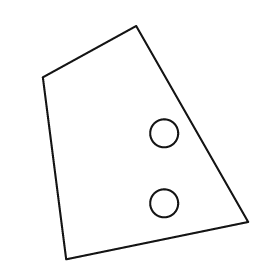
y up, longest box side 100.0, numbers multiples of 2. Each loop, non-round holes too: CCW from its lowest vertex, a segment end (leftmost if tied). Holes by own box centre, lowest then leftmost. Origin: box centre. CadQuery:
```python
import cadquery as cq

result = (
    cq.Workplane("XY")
    .moveTo(-34.0, -50.0)
    .lineTo(44.0, -34.0)
    .lineTo(-4.0, 50.0)
    .lineTo(-44.0, 28.0)
    .close()
    .moveTo(8.0, -26.0)
    .circle(6.0)
    .moveTo(8.0, 4.0)
    .circle(6.0)
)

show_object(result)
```